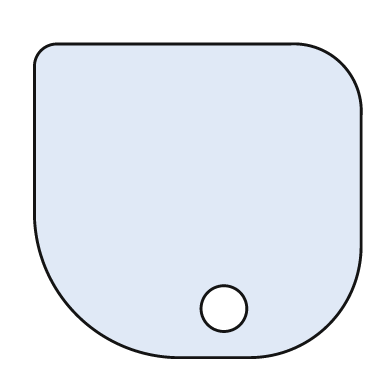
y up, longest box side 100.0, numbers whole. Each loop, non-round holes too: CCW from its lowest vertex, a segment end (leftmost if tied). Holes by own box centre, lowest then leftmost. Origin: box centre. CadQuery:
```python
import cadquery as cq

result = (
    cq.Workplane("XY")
    .moveTo(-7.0, -48.0)
    .lineTo(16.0, -48.0)
    .threePointArc((40.0, -38.0), (50.0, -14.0))
    .lineTo(50.0, 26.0)
    .threePointArc((44.0, 42.0), (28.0, 48.0))
    .lineTo(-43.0, 48.0)
    .threePointArc((-48.0, 46.0), (-50.0, 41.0))
    .lineTo(-50.0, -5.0)
    .threePointArc((-37.0, -35.0), (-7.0, -48.0))
    .close()
    .moveTo(8.0, -33.0)
    .circle(7.0)
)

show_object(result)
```